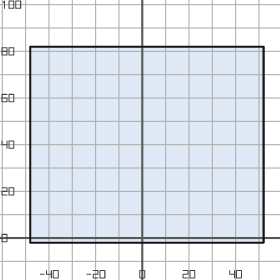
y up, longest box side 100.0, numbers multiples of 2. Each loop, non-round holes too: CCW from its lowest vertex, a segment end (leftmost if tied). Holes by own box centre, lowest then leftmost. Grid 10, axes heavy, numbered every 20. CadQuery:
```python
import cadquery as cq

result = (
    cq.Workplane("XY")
    .moveTo(-48.0, -2.0)
    .lineTo(52.0, -2.0)
    .lineTo(52.0, 82.0)
    .lineTo(-48.0, 82.0)
    .close()
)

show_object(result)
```